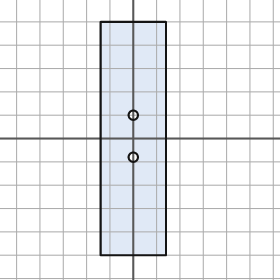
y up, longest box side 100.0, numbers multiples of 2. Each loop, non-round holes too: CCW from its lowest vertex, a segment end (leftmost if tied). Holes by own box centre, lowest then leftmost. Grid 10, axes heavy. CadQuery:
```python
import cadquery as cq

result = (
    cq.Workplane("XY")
    .moveTo(-14.0, -50.0)
    .lineTo(14.0, -50.0)
    .lineTo(14.0, 50.0)
    .lineTo(-14.0, 50.0)
    .close()
    .moveTo(0.0, -8.0)
    .circle(2.0)
    .moveTo(0.0, 10.0)
    .circle(2.0)
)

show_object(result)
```